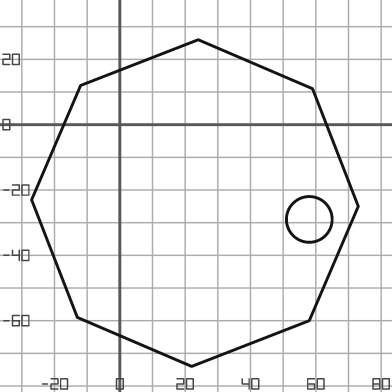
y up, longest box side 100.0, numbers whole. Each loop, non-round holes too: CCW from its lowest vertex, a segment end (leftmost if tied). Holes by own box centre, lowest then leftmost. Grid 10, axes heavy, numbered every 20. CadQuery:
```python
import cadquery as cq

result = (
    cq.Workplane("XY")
    .moveTo(22.0, -74.0)
    .lineTo(58.0, -60.0)
    .lineTo(73.0, -25.0)
    .lineTo(59.0, 11.0)
    .lineTo(24.0, 26.0)
    .lineTo(-12.0, 12.0)
    .lineTo(-27.0, -23.0)
    .lineTo(-13.0, -59.0)
    .close()
    .moveTo(58.0, -29.0)
    .circle(7.0)
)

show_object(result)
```